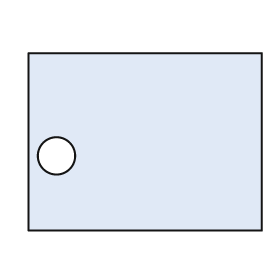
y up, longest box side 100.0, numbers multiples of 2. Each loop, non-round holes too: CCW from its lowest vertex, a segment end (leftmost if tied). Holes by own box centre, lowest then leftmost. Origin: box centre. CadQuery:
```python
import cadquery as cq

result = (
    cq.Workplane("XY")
    .moveTo(-50.0, -38.0)
    .lineTo(50.0, -38.0)
    .lineTo(50.0, 38.0)
    .lineTo(-50.0, 38.0)
    .close()
    .moveTo(-38.0, -6.0)
    .circle(8.0)
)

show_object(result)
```